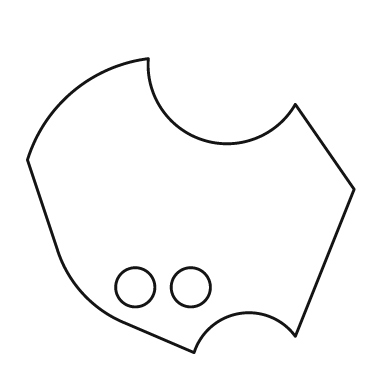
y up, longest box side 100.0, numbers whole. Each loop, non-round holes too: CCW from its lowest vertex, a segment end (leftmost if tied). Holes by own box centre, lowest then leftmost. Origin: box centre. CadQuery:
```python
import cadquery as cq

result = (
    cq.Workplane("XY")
    .moveTo(1.0, -45.0)
    .threePointArc((15.0, -33.0), (32.0, -40.0))
    .lineTo(50.0, 5.0)
    .lineTo(32.0, 31.0)
    .threePointArc((4.0, 20.0), (-13.0, 45.0))
    .threePointArc((-36.0, 35.0), (-50.0, 14.0))
    .lineTo(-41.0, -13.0)
    .threePointArc((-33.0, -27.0), (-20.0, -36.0))
    .close()
    .moveTo(-17.0, -25.0)
    .circle(6.0)
    .moveTo(0.0, -25.0)
    .circle(6.0)
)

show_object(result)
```